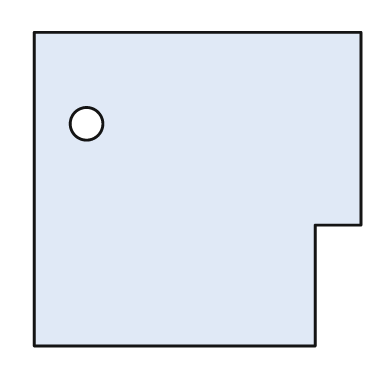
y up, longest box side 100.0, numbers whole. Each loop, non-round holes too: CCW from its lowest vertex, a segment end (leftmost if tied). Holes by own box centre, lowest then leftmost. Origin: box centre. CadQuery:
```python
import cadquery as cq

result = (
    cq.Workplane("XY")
    .moveTo(-50.0, -48.0)
    .lineTo(36.0, -48.0)
    .lineTo(36.0, -11.0)
    .lineTo(50.0, -11.0)
    .lineTo(50.0, 48.0)
    .lineTo(-50.0, 48.0)
    .close()
    .moveTo(-34.0, 20.0)
    .circle(5.0)
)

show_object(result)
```